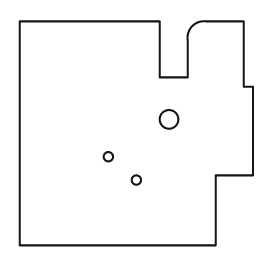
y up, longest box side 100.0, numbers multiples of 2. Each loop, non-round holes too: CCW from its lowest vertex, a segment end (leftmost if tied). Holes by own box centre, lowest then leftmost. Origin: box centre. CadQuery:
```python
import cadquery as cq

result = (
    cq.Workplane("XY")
    .moveTo(-50.0, -48.0)
    .lineTo(34.0, -48.0)
    .lineTo(34.0, -18.0)
    .lineTo(50.0, -18.0)
    .lineTo(50.0, 20.0)
    .lineTo(46.0, 20.0)
    .lineTo(46.0, 48.0)
    .lineTo(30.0, 48.0)
    .threePointArc((24.0, 46.0), (22.0, 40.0))
    .lineTo(22.0, 24.0)
    .lineTo(10.0, 24.0)
    .lineTo(10.0, 48.0)
    .lineTo(-50.0, 48.0)
    .close()
    .moveTo(0.0, -20.0)
    .circle(2.0)
    .moveTo(-12.0, -10.0)
    .circle(2.0)
    .moveTo(14.0, 6.0)
    .circle(4.0)
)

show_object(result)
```